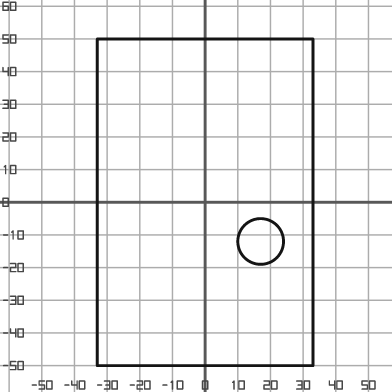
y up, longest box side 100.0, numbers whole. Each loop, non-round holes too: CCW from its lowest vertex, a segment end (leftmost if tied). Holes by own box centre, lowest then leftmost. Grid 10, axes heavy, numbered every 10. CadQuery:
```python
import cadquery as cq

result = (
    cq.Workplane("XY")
    .moveTo(-33.0, -50.0)
    .lineTo(33.0, -50.0)
    .lineTo(33.0, 50.0)
    .lineTo(-33.0, 50.0)
    .close()
    .moveTo(17.0, -12.0)
    .circle(7.0)
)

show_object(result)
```